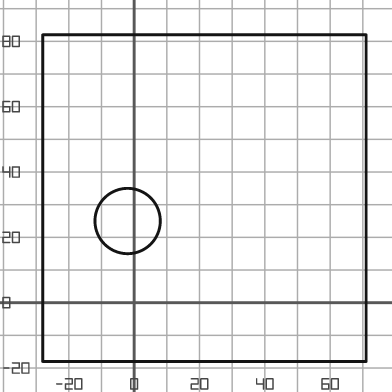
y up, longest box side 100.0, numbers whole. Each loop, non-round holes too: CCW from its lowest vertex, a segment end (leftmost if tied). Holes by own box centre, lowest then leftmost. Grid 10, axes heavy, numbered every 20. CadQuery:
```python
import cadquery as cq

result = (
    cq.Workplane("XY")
    .moveTo(-28.0, -18.0)
    .lineTo(71.0, -18.0)
    .lineTo(71.0, 82.0)
    .lineTo(-28.0, 82.0)
    .close()
    .moveTo(-2.0, 25.0)
    .circle(10.0)
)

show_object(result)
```